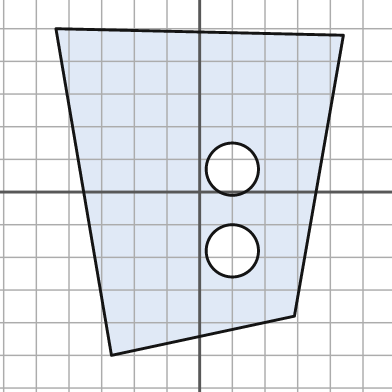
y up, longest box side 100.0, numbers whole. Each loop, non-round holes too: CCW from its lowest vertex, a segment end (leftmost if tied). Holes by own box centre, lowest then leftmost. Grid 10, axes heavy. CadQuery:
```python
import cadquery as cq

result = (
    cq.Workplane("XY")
    .moveTo(-27.0, -50.0)
    .lineTo(29.0, -38.0)
    .lineTo(44.0, 48.0)
    .lineTo(-44.0, 50.0)
    .close()
    .moveTo(10.0, -18.0)
    .circle(8.0)
    .moveTo(10.0, 7.0)
    .circle(8.0)
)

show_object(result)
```